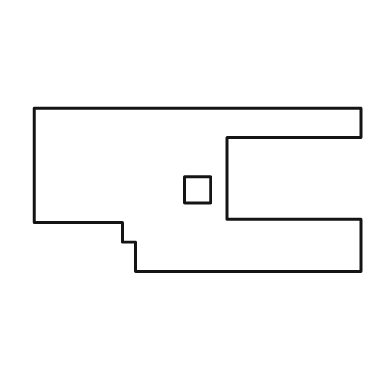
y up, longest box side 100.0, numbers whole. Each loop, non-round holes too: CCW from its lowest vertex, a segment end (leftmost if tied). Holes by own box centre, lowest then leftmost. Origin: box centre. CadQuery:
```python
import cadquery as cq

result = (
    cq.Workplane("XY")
    .moveTo(-19.0, -25.0)
    .lineTo(50.0, -25.0)
    .lineTo(50.0, -9.0)
    .lineTo(9.0, -9.0)
    .lineTo(9.0, 16.0)
    .lineTo(50.0, 16.0)
    .lineTo(50.0, 25.0)
    .lineTo(-50.0, 25.0)
    .lineTo(-50.0, -10.0)
    .lineTo(-23.0, -10.0)
    .lineTo(-23.0, -16.0)
    .lineTo(-19.0, -16.0)
    .close()
    .moveTo(-4.0, -4.0)
    .lineTo(4.0, -4.0)
    .lineTo(4.0, 4.0)
    .lineTo(-4.0, 4.0)
    .close()
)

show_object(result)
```